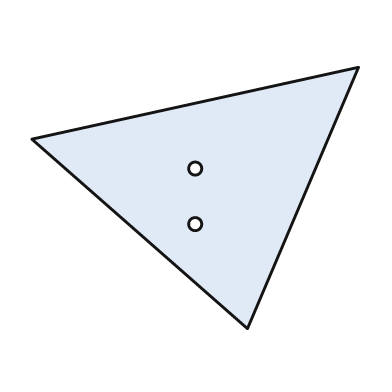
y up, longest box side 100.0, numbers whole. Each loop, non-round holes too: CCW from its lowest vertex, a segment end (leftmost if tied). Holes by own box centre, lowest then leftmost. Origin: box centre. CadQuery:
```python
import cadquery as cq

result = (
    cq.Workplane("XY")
    .moveTo(16.0, -40.0)
    .lineTo(50.0, 40.0)
    .lineTo(-50.0, 18.0)
    .close()
    .moveTo(0.0, -8.0)
    .circle(2.0)
    .moveTo(0.0, 9.0)
    .circle(2.0)
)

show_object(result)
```